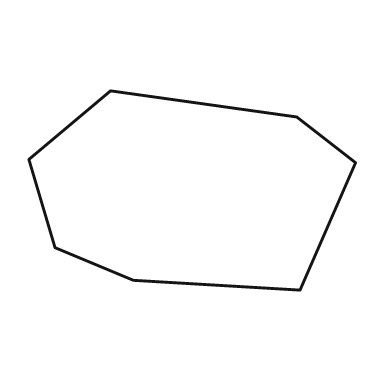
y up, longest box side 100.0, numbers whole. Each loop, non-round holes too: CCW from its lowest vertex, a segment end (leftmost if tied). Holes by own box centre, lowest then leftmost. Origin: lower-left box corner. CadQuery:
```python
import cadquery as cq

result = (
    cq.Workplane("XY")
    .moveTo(83.0, 0.0)
    .lineTo(100.0, 39.0)
    .lineTo(82.0, 53.0)
    .lineTo(25.0, 61.0)
    .lineTo(0.0, 40.0)
    .lineTo(8.0, 13.0)
    .lineTo(32.0, 3.0)
    .close()
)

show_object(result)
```